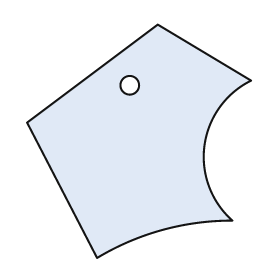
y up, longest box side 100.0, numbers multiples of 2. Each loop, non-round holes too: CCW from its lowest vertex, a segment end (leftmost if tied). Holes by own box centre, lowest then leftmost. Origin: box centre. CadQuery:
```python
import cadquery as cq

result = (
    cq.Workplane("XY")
    .moveTo(-18.0, -50.0)
    .threePointArc((10.0, -38.0), (40.0, -34.0))
    .threePointArc((28.0, -2.0), (48.0, 26.0))
    .lineTo(8.0, 50.0)
    .lineTo(-48.0, 8.0)
    .close()
    .moveTo(-4.0, 24.0)
    .circle(4.0)
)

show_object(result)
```